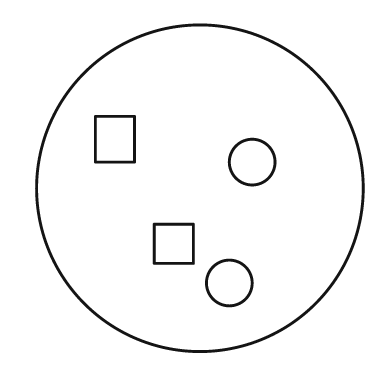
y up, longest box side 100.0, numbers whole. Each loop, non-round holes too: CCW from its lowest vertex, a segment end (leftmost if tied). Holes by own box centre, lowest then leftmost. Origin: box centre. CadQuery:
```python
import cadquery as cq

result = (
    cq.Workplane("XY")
    .moveTo(0.0, 0.0)
    .circle(50.0)
    .moveTo(9.0, -29.0)
    .circle(7.0)
    .moveTo(-14.0, -23.0)
    .lineTo(-2.0, -23.0)
    .lineTo(-2.0, -11.0)
    .lineTo(-14.0, -11.0)
    .close()
    .moveTo(16.0, 8.0)
    .circle(7.0)
    .moveTo(-32.0, 8.0)
    .lineTo(-20.0, 8.0)
    .lineTo(-20.0, 22.0)
    .lineTo(-32.0, 22.0)
    .close()
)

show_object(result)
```